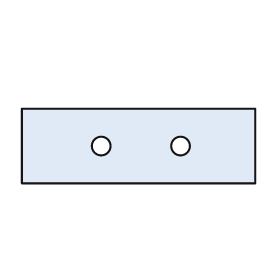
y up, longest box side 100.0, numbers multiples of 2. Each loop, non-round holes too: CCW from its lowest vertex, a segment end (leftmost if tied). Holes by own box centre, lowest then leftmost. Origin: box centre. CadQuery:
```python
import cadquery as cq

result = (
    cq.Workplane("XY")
    .moveTo(-50.0, -16.0)
    .lineTo(50.0, -16.0)
    .lineTo(50.0, 16.0)
    .lineTo(-50.0, 16.0)
    .close()
    .moveTo(-16.0, 0.0)
    .circle(4.0)
    .moveTo(18.0, 0.0)
    .circle(4.0)
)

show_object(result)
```